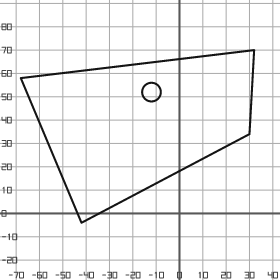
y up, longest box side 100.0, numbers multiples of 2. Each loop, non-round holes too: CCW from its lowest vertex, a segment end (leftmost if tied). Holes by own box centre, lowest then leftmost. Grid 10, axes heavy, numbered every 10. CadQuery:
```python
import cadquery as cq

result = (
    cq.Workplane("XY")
    .moveTo(-42.0, -4.0)
    .lineTo(30.0, 34.0)
    .lineTo(32.0, 70.0)
    .lineTo(-68.0, 58.0)
    .close()
    .moveTo(-12.0, 52.0)
    .circle(4.0)
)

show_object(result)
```